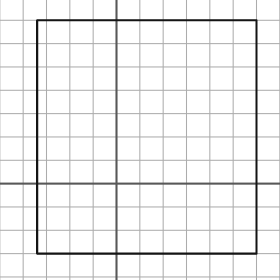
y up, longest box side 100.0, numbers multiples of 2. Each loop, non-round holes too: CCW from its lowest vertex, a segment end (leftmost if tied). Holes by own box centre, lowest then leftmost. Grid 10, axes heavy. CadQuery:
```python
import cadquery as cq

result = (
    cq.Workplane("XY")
    .moveTo(-34.0, -30.0)
    .lineTo(60.0, -30.0)
    .lineTo(60.0, 70.0)
    .lineTo(-34.0, 70.0)
    .close()
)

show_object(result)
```